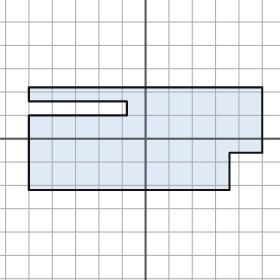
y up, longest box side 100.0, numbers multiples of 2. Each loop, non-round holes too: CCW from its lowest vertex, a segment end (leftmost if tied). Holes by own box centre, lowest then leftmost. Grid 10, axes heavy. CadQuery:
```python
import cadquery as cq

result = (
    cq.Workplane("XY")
    .moveTo(-50.0, -22.0)
    .lineTo(36.0, -22.0)
    .lineTo(36.0, -6.0)
    .lineTo(50.0, -6.0)
    .lineTo(50.0, 22.0)
    .lineTo(-50.0, 22.0)
    .lineTo(-50.0, 16.0)
    .lineTo(-8.0, 16.0)
    .lineTo(-8.0, 10.0)
    .lineTo(-50.0, 10.0)
    .close()
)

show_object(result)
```